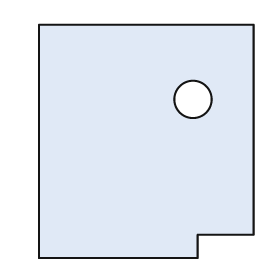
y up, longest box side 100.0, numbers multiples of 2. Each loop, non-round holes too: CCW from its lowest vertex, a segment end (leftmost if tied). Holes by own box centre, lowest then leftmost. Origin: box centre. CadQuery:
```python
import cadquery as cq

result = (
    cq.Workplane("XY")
    .moveTo(-46.0, -50.0)
    .lineTo(22.0, -50.0)
    .lineTo(22.0, -40.0)
    .lineTo(46.0, -40.0)
    .lineTo(46.0, 50.0)
    .lineTo(-46.0, 50.0)
    .close()
    .moveTo(20.0, 18.0)
    .circle(8.0)
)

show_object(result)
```